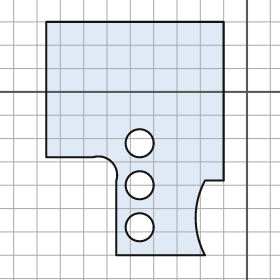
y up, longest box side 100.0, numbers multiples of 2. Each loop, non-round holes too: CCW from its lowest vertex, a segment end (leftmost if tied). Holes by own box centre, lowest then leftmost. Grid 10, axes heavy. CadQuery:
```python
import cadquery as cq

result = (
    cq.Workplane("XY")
    .moveTo(-56.0, -70.0)
    .lineTo(-18.0, -70.0)
    .threePointArc((-22.0, -54.0), (-18.0, -38.0))
    .lineTo(-10.0, -38.0)
    .lineTo(-10.0, 30.0)
    .lineTo(-86.0, 30.0)
    .lineTo(-86.0, -28.0)
    .lineTo(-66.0, -28.0)
    .threePointArc((-58.0, -30.0), (-56.0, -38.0))
    .close()
    .moveTo(-46.0, -58.0)
    .circle(6.0)
    .moveTo(-46.0, -40.0)
    .circle(6.0)
    .moveTo(-46.0, -22.0)
    .circle(6.0)
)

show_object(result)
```